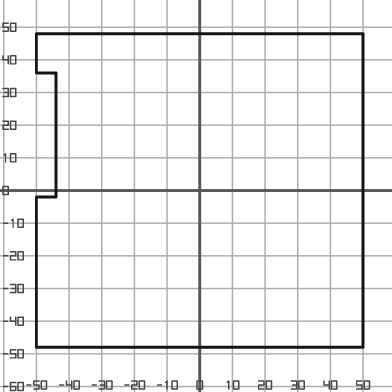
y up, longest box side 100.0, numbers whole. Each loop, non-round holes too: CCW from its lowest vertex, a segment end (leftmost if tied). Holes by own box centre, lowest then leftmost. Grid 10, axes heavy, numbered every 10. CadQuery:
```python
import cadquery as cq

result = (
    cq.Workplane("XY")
    .moveTo(-50.0, -48.0)
    .lineTo(50.0, -48.0)
    .lineTo(50.0, 48.0)
    .lineTo(-50.0, 48.0)
    .lineTo(-50.0, 36.0)
    .lineTo(-44.0, 36.0)
    .lineTo(-44.0, -2.0)
    .lineTo(-50.0, -2.0)
    .close()
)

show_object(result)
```